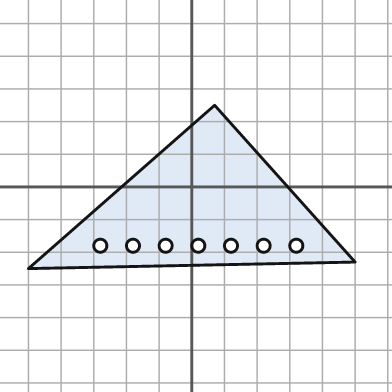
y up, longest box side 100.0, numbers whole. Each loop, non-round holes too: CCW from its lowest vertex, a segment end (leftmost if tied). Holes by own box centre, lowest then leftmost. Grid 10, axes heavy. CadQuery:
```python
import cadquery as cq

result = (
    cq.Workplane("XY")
    .moveTo(-50.0, -25.0)
    .lineTo(50.0, -23.0)
    .lineTo(7.0, 25.0)
    .close()
    .moveTo(-28.0, -18.0)
    .circle(2.0)
    .moveTo(-18.0, -18.0)
    .circle(2.0)
    .moveTo(-8.0, -18.0)
    .circle(2.0)
    .moveTo(2.0, -18.0)
    .circle(2.0)
    .moveTo(12.0, -18.0)
    .circle(2.0)
    .moveTo(22.0, -18.0)
    .circle(2.0)
    .moveTo(32.0, -18.0)
    .circle(2.0)
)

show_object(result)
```